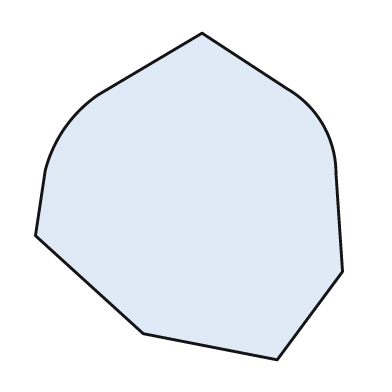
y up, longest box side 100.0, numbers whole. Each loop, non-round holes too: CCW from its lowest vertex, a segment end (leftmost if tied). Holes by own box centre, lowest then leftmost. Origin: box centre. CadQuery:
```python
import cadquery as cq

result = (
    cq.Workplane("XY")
    .moveTo(27.0, -50.0)
    .lineTo(47.0, -23.0)
    .lineTo(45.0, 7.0)
    .threePointArc((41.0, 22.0), (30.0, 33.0))
    .lineTo(4.0, 50.0)
    .lineTo(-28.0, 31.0)
    .threePointArc((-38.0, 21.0), (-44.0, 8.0))
    .lineTo(-47.0, -12.0)
    .lineTo(-14.0, -42.0)
    .close()
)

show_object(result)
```